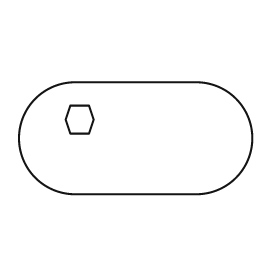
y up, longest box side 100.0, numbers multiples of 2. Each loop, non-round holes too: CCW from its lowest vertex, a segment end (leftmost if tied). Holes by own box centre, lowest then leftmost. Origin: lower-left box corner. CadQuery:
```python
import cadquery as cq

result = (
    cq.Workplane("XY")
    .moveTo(24.0, 0.0)
    .lineTo(76.0, 0.0)
    .threePointArc((100.0, 24.0), (76.0, 48.0))
    .lineTo(24.0, 48.0)
    .threePointArc((0.0, 24.0), (24.0, 0.0))
    .close()
    .moveTo(22.0, 26.0)
    .lineTo(30.0, 26.0)
    .lineTo(32.0, 32.0)
    .lineTo(30.0, 38.0)
    .lineTo(22.0, 38.0)
    .lineTo(20.0, 32.0)
    .close()
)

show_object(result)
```